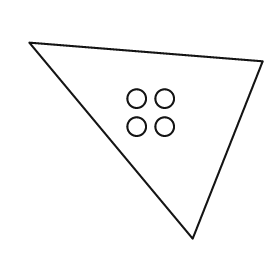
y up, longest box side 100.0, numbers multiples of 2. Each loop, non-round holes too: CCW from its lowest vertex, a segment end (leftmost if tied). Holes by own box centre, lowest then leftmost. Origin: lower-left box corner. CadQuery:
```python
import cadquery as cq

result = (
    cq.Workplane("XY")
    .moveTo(70.0, 0.0)
    .lineTo(100.0, 76.0)
    .lineTo(0.0, 84.0)
    .close()
    .moveTo(46.0, 48.0)
    .circle(4.0)
    .moveTo(58.0, 48.0)
    .circle(4.0)
    .moveTo(46.0, 60.0)
    .circle(4.0)
    .moveTo(58.0, 60.0)
    .circle(4.0)
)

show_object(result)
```